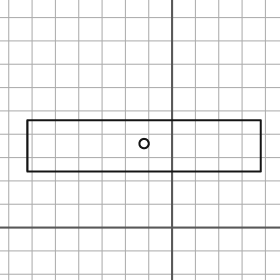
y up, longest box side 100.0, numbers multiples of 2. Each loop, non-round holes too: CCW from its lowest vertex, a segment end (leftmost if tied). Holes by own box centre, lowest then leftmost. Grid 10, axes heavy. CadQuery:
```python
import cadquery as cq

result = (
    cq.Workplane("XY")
    .moveTo(-62.0, 24.0)
    .lineTo(38.0, 24.0)
    .lineTo(38.0, 46.0)
    .lineTo(-62.0, 46.0)
    .close()
    .moveTo(-12.0, 36.0)
    .circle(2.0)
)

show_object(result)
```